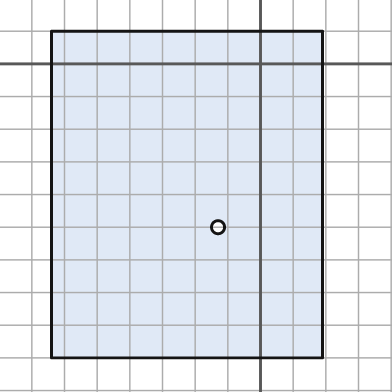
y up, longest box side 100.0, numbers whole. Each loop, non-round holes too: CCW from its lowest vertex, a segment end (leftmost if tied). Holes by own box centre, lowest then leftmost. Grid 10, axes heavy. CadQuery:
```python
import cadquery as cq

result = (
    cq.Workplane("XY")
    .moveTo(-64.0, -90.0)
    .lineTo(19.0, -90.0)
    .lineTo(19.0, 10.0)
    .lineTo(-64.0, 10.0)
    .close()
    .moveTo(-13.0, -50.0)
    .circle(2.0)
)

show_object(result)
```